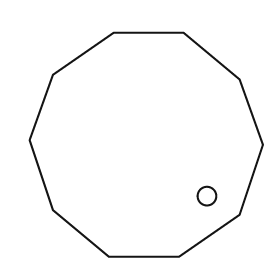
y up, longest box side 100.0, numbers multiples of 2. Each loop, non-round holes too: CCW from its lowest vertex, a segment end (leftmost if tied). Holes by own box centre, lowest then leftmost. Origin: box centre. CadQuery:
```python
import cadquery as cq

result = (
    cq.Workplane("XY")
    .moveTo(-16.0, -48.0)
    .lineTo(14.0, -48.0)
    .lineTo(40.0, -30.0)
    .lineTo(50.0, 0.0)
    .lineTo(40.0, 28.0)
    .lineTo(16.0, 48.0)
    .lineTo(-14.0, 48.0)
    .lineTo(-40.0, 30.0)
    .lineTo(-50.0, 2.0)
    .lineTo(-40.0, -28.0)
    .close()
    .moveTo(26.0, -22.0)
    .circle(4.0)
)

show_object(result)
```